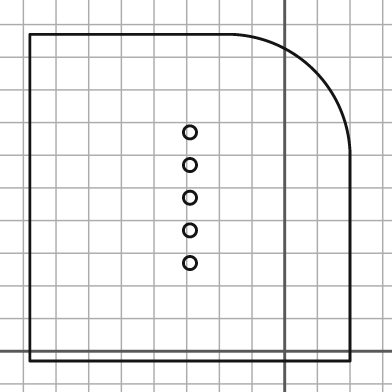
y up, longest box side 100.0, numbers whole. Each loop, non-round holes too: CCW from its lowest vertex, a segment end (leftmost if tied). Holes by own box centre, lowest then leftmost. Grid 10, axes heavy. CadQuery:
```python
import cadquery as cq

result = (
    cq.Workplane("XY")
    .moveTo(-78.0, -3.0)
    .lineTo(20.0, -3.0)
    .lineTo(20.0, 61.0)
    .threePointArc((9.0, 86.0), (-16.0, 97.0))
    .lineTo(-78.0, 97.0)
    .close()
    .moveTo(-29.0, 27.0)
    .circle(2.0)
    .moveTo(-29.0, 37.0)
    .circle(2.0)
    .moveTo(-29.0, 47.0)
    .circle(2.0)
    .moveTo(-29.0, 57.0)
    .circle(2.0)
    .moveTo(-29.0, 67.0)
    .circle(2.0)
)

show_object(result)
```